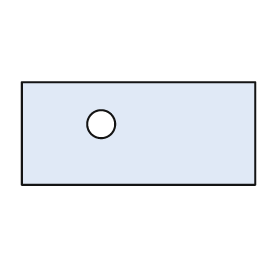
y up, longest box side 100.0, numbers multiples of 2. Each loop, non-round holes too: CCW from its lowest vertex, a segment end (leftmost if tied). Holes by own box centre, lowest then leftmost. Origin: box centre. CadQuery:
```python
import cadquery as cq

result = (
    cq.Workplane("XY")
    .moveTo(-50.0, -22.0)
    .lineTo(50.0, -22.0)
    .lineTo(50.0, 22.0)
    .lineTo(-50.0, 22.0)
    .close()
    .moveTo(-16.0, 4.0)
    .circle(6.0)
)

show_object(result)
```